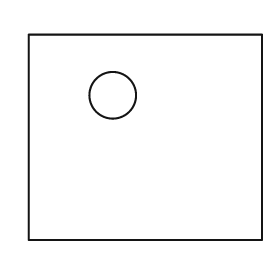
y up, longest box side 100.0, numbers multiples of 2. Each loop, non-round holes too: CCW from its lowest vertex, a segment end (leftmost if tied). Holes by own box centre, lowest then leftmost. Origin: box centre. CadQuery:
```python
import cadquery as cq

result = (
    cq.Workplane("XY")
    .moveTo(-50.0, -44.0)
    .lineTo(50.0, -44.0)
    .lineTo(50.0, 44.0)
    .lineTo(-50.0, 44.0)
    .close()
    .moveTo(-14.0, 18.0)
    .circle(10.0)
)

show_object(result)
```